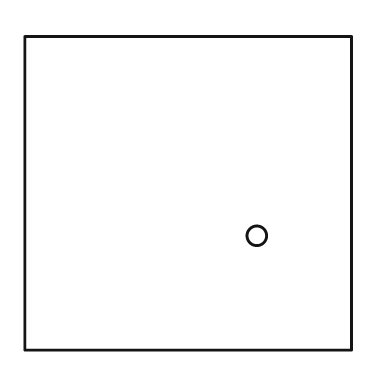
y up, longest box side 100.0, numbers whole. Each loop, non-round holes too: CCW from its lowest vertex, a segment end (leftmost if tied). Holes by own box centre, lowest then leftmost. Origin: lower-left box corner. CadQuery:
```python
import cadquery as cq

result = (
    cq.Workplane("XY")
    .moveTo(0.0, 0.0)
    .lineTo(100.0, 0.0)
    .lineTo(100.0, 96.0)
    .lineTo(0.0, 96.0)
    .close()
    .moveTo(71.0, 35.0)
    .circle(3.0)
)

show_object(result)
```